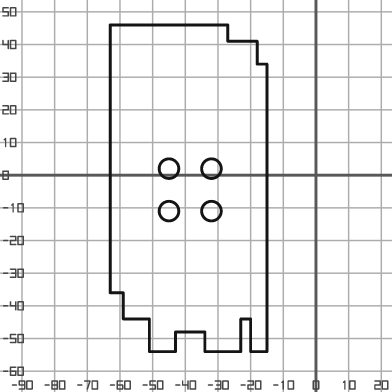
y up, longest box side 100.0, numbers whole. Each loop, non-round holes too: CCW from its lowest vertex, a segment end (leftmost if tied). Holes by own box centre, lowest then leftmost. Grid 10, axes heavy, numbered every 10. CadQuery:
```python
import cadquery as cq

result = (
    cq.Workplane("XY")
    .moveTo(-51.0, -54.0)
    .lineTo(-43.0, -54.0)
    .lineTo(-43.0, -48.0)
    .lineTo(-34.0, -48.0)
    .lineTo(-34.0, -54.0)
    .lineTo(-23.0, -54.0)
    .lineTo(-23.0, -44.0)
    .lineTo(-20.0, -44.0)
    .lineTo(-20.0, -54.0)
    .lineTo(-15.0, -54.0)
    .lineTo(-15.0, 34.0)
    .lineTo(-18.0, 34.0)
    .lineTo(-18.0, 41.0)
    .lineTo(-27.0, 41.0)
    .lineTo(-27.0, 46.0)
    .lineTo(-63.0, 46.0)
    .lineTo(-63.0, -36.0)
    .lineTo(-59.0, -36.0)
    .lineTo(-59.0, -44.0)
    .lineTo(-51.0, -44.0)
    .close()
    .moveTo(-45.0, -11.0)
    .circle(3.0)
    .moveTo(-32.0, -11.0)
    .circle(3.0)
    .moveTo(-45.0, 2.0)
    .circle(3.0)
    .moveTo(-32.0, 2.0)
    .circle(3.0)
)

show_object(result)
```